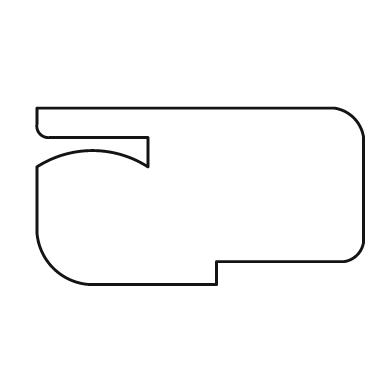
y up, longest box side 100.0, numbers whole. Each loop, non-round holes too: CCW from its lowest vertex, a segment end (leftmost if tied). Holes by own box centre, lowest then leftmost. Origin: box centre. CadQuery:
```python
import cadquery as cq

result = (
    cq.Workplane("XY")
    .moveTo(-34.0, -27.0)
    .lineTo(5.0, -27.0)
    .lineTo(5.0, -20.0)
    .lineTo(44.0, -20.0)
    .threePointArc((48.0, -18.0), (50.0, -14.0))
    .lineTo(50.0, 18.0)
    .threePointArc((47.0, 24.0), (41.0, 27.0))
    .lineTo(-50.0, 27.0)
    .lineTo(-50.0, 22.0)
    .threePointArc((-49.0, 19.0), (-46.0, 18.0))
    .lineTo(-16.0, 18.0)
    .lineTo(-16.0, 9.0)
    .threePointArc((-33.0, 14.0), (-50.0, 9.0))
    .lineTo(-50.0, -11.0)
    .threePointArc((-45.0, -22.0), (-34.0, -27.0))
    .close()
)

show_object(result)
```